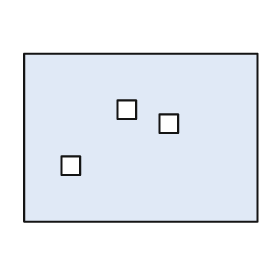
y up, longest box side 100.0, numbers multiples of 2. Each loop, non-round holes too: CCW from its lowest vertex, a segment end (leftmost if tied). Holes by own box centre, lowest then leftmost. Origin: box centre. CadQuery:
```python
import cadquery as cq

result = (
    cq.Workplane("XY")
    .moveTo(-50.0, -36.0)
    .lineTo(50.0, -36.0)
    .lineTo(50.0, 36.0)
    .lineTo(-50.0, 36.0)
    .close()
    .moveTo(-34.0, -16.0)
    .lineTo(-26.0, -16.0)
    .lineTo(-26.0, -8.0)
    .lineTo(-34.0, -8.0)
    .close()
    .moveTo(8.0, 2.0)
    .lineTo(16.0, 2.0)
    .lineTo(16.0, 10.0)
    .lineTo(8.0, 10.0)
    .close()
    .moveTo(-10.0, 8.0)
    .lineTo(-2.0, 8.0)
    .lineTo(-2.0, 16.0)
    .lineTo(-10.0, 16.0)
    .close()
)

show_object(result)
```